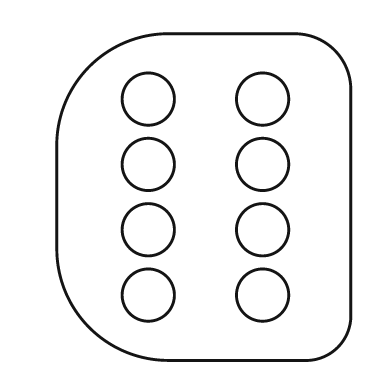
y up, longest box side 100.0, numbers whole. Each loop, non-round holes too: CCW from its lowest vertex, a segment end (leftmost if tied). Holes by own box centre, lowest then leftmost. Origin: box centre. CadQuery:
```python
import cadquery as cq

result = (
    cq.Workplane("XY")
    .moveTo(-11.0, -50.0)
    .lineTo(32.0, -50.0)
    .threePointArc((41.0, -46.0), (45.0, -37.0))
    .lineTo(45.0, 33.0)
    .threePointArc((40.0, 45.0), (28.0, 50.0))
    .lineTo(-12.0, 50.0)
    .threePointArc((-35.0, 40.0), (-45.0, 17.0))
    .lineTo(-45.0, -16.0)
    .threePointArc((-35.0, -40.0), (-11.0, -50.0))
    .close()
    .moveTo(-17.0, -30.0)
    .circle(8.0)
    .moveTo(18.0, -30.0)
    .circle(8.0)
    .moveTo(-17.0, -10.0)
    .circle(8.0)
    .moveTo(18.0, -10.0)
    .circle(8.0)
    .moveTo(-17.0, 10.0)
    .circle(8.0)
    .moveTo(18.0, 10.0)
    .circle(8.0)
    .moveTo(-17.0, 30.0)
    .circle(8.0)
    .moveTo(18.0, 30.0)
    .circle(8.0)
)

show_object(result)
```